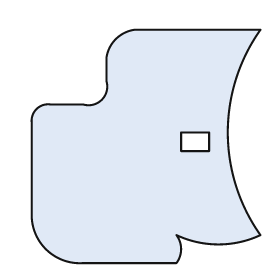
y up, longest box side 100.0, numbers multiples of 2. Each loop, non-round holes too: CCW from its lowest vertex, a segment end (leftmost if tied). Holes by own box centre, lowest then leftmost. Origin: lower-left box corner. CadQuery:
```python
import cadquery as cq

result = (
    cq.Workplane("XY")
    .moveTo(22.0, 0.0)
    .lineTo(62.0, 0.0)
    .threePointArc((64.0, 6.0), (62.0, 12.0))
    .threePointArc((80.0, 8.0), (98.0, 12.0))
    .threePointArc((84.0, 56.0), (98.0, 100.0))
    .lineTo(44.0, 100.0)
    .threePointArc((36.0, 96.0), (32.0, 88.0))
    .lineTo(32.0, 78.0)
    .threePointArc((30.0, 70.0), (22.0, 68.0))
    .lineTo(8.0, 68.0)
    .threePointArc((2.0, 66.0), (0.0, 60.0))
    .lineTo(0.0, 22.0)
    .threePointArc((6.0, 6.0), (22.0, 0.0))
    .close()
    .moveTo(64.0, 48.0)
    .lineTo(76.0, 48.0)
    .lineTo(76.0, 56.0)
    .lineTo(64.0, 56.0)
    .close()
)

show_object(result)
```